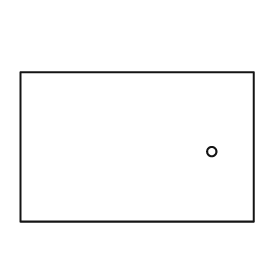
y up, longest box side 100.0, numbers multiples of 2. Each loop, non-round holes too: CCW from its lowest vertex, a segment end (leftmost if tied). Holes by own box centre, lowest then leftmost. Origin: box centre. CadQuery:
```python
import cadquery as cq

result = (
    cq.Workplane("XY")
    .moveTo(-50.0, -32.0)
    .lineTo(50.0, -32.0)
    .lineTo(50.0, 32.0)
    .lineTo(-50.0, 32.0)
    .close()
    .moveTo(32.0, -2.0)
    .circle(2.0)
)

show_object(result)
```